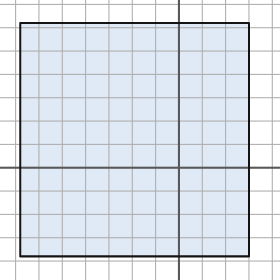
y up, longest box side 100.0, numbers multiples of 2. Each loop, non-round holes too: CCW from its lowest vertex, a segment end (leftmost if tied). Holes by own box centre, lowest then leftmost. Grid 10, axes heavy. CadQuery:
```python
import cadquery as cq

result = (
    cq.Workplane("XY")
    .moveTo(-68.0, -38.0)
    .lineTo(30.0, -38.0)
    .lineTo(30.0, 62.0)
    .lineTo(-68.0, 62.0)
    .close()
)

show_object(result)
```